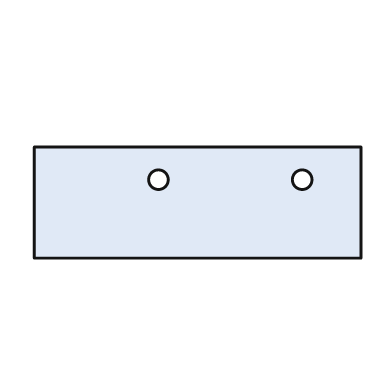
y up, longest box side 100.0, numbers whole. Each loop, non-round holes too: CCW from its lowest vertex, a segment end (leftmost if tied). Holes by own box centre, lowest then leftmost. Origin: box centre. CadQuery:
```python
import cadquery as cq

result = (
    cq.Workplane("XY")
    .moveTo(-50.0, -17.0)
    .lineTo(50.0, -17.0)
    .lineTo(50.0, 17.0)
    .lineTo(-50.0, 17.0)
    .close()
    .moveTo(-12.0, 7.0)
    .circle(3.0)
    .moveTo(32.0, 7.0)
    .circle(3.0)
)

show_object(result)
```